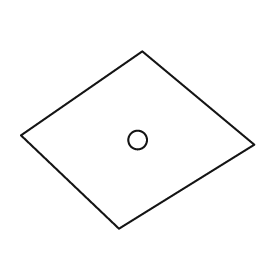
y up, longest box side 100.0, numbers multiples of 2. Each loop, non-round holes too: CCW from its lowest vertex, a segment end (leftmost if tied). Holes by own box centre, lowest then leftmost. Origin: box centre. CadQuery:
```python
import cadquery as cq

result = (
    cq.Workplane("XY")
    .moveTo(-8.0, -38.0)
    .lineTo(50.0, -2.0)
    .lineTo(2.0, 38.0)
    .lineTo(-50.0, 2.0)
    .close()
    .moveTo(0.0, 0.0)
    .circle(4.0)
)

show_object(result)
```